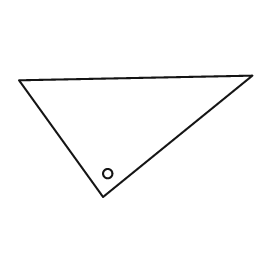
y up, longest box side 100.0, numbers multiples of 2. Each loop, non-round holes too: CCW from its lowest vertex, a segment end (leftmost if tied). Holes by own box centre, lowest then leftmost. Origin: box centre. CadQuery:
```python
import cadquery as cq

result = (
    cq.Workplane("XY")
    .moveTo(-14.0, -26.0)
    .lineTo(50.0, 26.0)
    .lineTo(-50.0, 24.0)
    .close()
    .moveTo(-12.0, -16.0)
    .circle(2.0)
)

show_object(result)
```